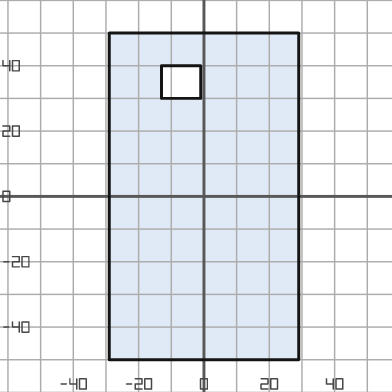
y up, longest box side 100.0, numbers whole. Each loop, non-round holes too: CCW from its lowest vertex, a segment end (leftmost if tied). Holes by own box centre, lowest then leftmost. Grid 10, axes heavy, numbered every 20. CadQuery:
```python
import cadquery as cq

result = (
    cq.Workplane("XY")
    .moveTo(-29.0, -50.0)
    .lineTo(29.0, -50.0)
    .lineTo(29.0, 50.0)
    .lineTo(-29.0, 50.0)
    .close()
    .moveTo(-13.0, 30.0)
    .lineTo(-1.0, 30.0)
    .lineTo(-1.0, 40.0)
    .lineTo(-13.0, 40.0)
    .close()
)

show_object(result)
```